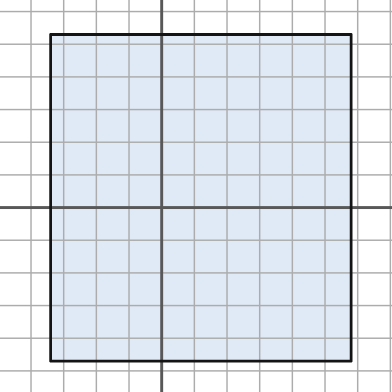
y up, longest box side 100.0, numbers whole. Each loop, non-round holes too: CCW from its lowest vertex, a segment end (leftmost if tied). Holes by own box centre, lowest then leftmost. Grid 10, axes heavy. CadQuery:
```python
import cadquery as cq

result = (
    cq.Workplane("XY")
    .moveTo(-34.0, -47.0)
    .lineTo(58.0, -47.0)
    .lineTo(58.0, 53.0)
    .lineTo(-34.0, 53.0)
    .close()
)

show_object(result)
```